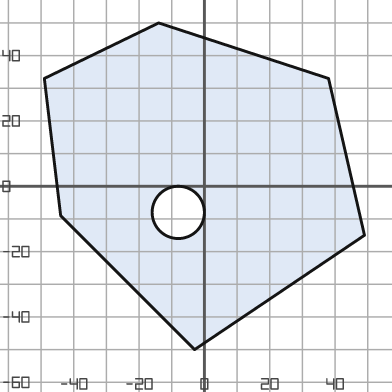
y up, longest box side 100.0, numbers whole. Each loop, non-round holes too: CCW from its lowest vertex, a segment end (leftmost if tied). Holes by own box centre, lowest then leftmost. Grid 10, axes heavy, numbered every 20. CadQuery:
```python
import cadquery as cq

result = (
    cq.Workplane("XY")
    .moveTo(-3.0, -50.0)
    .lineTo(49.0, -15.0)
    .lineTo(38.0, 33.0)
    .lineTo(-14.0, 50.0)
    .lineTo(-49.0, 33.0)
    .lineTo(-44.0, -9.0)
    .close()
    .moveTo(-8.0, -8.0)
    .circle(8.0)
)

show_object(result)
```